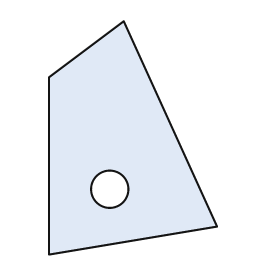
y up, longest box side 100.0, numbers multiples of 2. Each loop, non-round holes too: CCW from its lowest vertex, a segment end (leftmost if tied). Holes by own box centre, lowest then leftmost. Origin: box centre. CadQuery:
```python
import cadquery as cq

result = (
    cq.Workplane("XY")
    .moveTo(-36.0, -50.0)
    .lineTo(36.0, -38.0)
    .lineTo(-4.0, 50.0)
    .lineTo(-36.0, 26.0)
    .close()
    .moveTo(-10.0, -22.0)
    .circle(8.0)
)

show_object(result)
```